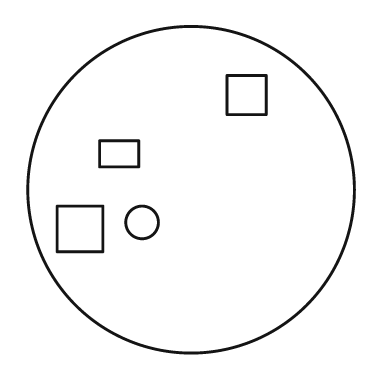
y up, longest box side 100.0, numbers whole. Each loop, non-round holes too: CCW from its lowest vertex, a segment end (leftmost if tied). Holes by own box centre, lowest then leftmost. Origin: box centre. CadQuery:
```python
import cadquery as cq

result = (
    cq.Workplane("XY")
    .moveTo(0.0, 0.0)
    .circle(50.0)
    .moveTo(-41.0, -19.0)
    .lineTo(-27.0, -19.0)
    .lineTo(-27.0, -5.0)
    .lineTo(-41.0, -5.0)
    .close()
    .moveTo(-15.0, -10.0)
    .circle(5.0)
    .moveTo(-28.0, 7.0)
    .lineTo(-16.0, 7.0)
    .lineTo(-16.0, 15.0)
    .lineTo(-28.0, 15.0)
    .close()
    .moveTo(11.0, 23.0)
    .lineTo(23.0, 23.0)
    .lineTo(23.0, 35.0)
    .lineTo(11.0, 35.0)
    .close()
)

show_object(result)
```